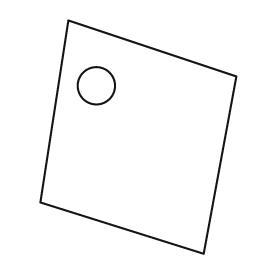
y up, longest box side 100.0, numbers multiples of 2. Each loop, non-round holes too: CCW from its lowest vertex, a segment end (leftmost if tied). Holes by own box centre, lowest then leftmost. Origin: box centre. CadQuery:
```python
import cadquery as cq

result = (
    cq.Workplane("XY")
    .moveTo(28.0, -50.0)
    .lineTo(42.0, 26.0)
    .lineTo(-30.0, 50.0)
    .lineTo(-42.0, -28.0)
    .close()
    .moveTo(-18.0, 22.0)
    .circle(8.0)
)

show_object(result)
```